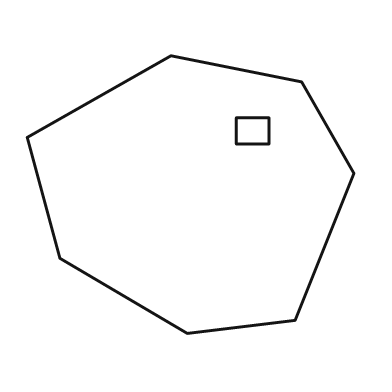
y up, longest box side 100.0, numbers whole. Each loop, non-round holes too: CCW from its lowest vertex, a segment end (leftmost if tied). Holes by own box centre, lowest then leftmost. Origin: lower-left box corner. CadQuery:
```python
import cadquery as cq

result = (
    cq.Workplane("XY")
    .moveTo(49.0, 0.0)
    .lineTo(82.0, 4.0)
    .lineTo(100.0, 49.0)
    .lineTo(84.0, 77.0)
    .lineTo(44.0, 85.0)
    .lineTo(0.0, 60.0)
    .lineTo(10.0, 23.0)
    .close()
    .moveTo(64.0, 58.0)
    .lineTo(74.0, 58.0)
    .lineTo(74.0, 66.0)
    .lineTo(64.0, 66.0)
    .close()
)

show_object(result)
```